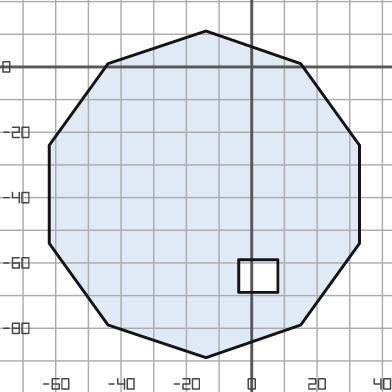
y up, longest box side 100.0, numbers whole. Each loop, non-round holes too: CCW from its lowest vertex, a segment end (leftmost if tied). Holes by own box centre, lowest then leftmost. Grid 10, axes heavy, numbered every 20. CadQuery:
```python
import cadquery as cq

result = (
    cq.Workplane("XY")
    .moveTo(-14.0, -89.0)
    .lineTo(15.0, -79.0)
    .lineTo(33.0, -54.0)
    .lineTo(33.0, -24.0)
    .lineTo(15.0, 1.0)
    .lineTo(-14.0, 11.0)
    .lineTo(-44.0, 1.0)
    .lineTo(-62.0, -24.0)
    .lineTo(-62.0, -54.0)
    .lineTo(-44.0, -79.0)
    .close()
    .moveTo(-4.0, -69.0)
    .lineTo(8.0, -69.0)
    .lineTo(8.0, -59.0)
    .lineTo(-4.0, -59.0)
    .close()
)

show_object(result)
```